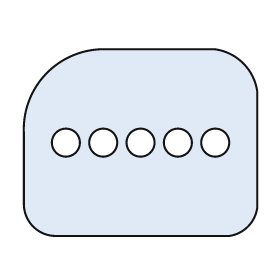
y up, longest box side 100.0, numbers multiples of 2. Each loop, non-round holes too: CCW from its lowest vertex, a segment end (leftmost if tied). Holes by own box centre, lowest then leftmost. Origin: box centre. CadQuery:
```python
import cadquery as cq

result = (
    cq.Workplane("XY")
    .moveTo(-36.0, -40.0)
    .lineTo(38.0, -40.0)
    .threePointArc((46.0, -36.0), (50.0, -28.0))
    .lineTo(50.0, 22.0)
    .threePointArc((44.0, 34.0), (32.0, 40.0))
    .lineTo(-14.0, 40.0)
    .threePointArc((-40.0, 30.0), (-50.0, 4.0))
    .lineTo(-50.0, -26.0)
    .threePointArc((-46.0, -36.0), (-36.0, -40.0))
    .close()
    .moveTo(-32.0, 0.0)
    .circle(6.0)
    .moveTo(-16.0, 0.0)
    .circle(6.0)
    .moveTo(0.0, 0.0)
    .circle(6.0)
    .moveTo(16.0, 0.0)
    .circle(6.0)
    .moveTo(32.0, 0.0)
    .circle(6.0)
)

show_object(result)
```